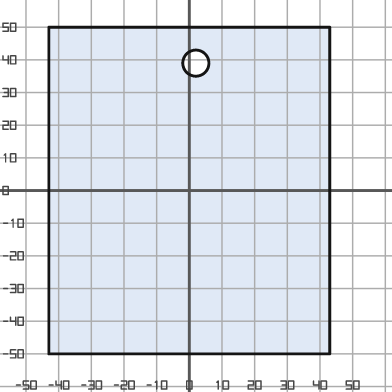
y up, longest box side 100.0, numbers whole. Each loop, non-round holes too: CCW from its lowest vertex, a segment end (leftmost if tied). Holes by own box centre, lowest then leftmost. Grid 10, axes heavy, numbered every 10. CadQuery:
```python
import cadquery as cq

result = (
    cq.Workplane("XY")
    .moveTo(-43.0, -50.0)
    .lineTo(43.0, -50.0)
    .lineTo(43.0, 50.0)
    .lineTo(-43.0, 50.0)
    .close()
    .moveTo(2.0, 39.0)
    .circle(4.0)
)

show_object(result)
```